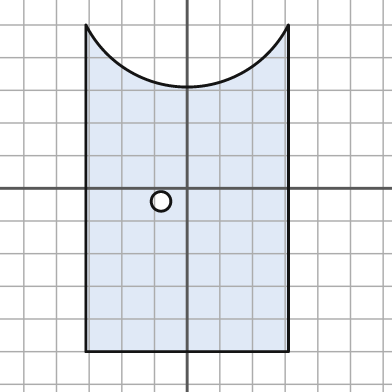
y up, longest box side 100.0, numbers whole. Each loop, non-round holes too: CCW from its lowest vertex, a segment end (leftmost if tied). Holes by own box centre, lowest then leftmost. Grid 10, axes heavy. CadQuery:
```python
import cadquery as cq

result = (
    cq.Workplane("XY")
    .moveTo(-31.0, -50.0)
    .lineTo(31.0, -50.0)
    .lineTo(31.0, 50.0)
    .threePointArc((0.0, 31.0), (-31.0, 50.0))
    .close()
    .moveTo(-8.0, -4.0)
    .circle(3.0)
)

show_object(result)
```